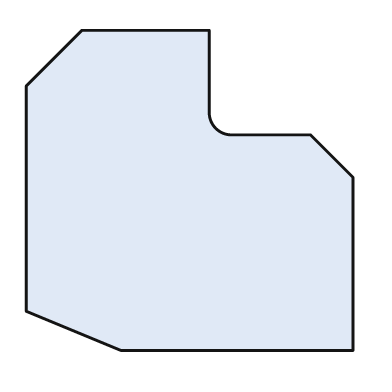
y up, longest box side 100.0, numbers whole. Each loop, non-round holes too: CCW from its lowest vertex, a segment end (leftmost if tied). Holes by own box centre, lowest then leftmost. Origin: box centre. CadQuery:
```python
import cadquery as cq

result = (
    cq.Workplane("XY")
    .moveTo(-21.0, -49.0)
    .lineTo(50.0, -49.0)
    .lineTo(50.0, 4.0)
    .lineTo(37.0, 17.0)
    .lineTo(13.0, 17.0)
    .threePointArc((8.0, 19.0), (6.0, 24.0))
    .lineTo(6.0, 49.0)
    .lineTo(-33.0, 49.0)
    .lineTo(-50.0, 32.0)
    .lineTo(-50.0, -37.0)
    .close()
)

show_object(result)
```